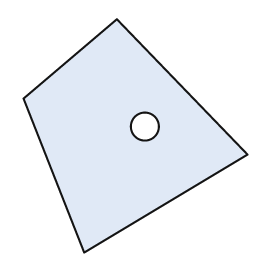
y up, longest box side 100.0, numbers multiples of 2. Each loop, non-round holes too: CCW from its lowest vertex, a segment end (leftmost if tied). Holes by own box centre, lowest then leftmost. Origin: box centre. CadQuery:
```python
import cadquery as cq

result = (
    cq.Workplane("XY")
    .moveTo(-22.0, -50.0)
    .lineTo(48.0, -8.0)
    .lineTo(-8.0, 50.0)
    .lineTo(-48.0, 16.0)
    .close()
    .moveTo(4.0, 4.0)
    .circle(6.0)
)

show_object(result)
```